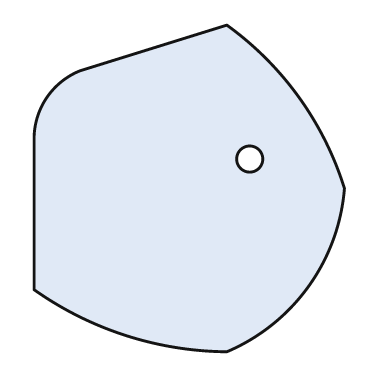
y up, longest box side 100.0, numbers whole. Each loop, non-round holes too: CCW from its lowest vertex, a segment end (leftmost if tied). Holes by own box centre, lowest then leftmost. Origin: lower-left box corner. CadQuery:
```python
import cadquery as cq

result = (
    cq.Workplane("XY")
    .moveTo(59.0, 0.0)
    .threePointArc((84.0, 20.0), (95.0, 50.0))
    .threePointArc((81.0, 78.0), (59.0, 100.0))
    .lineTo(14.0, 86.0)
    .threePointArc((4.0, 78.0), (0.0, 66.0))
    .lineTo(0.0, 19.0)
    .threePointArc((28.0, 5.0), (59.0, 0.0))
    .close()
    .moveTo(66.0, 59.0)
    .circle(4.0)
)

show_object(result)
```